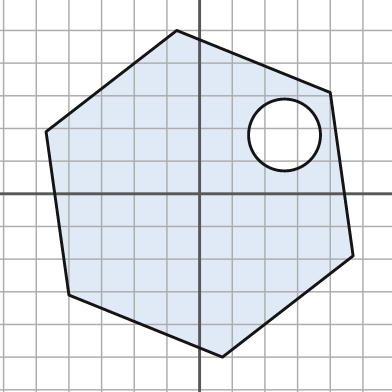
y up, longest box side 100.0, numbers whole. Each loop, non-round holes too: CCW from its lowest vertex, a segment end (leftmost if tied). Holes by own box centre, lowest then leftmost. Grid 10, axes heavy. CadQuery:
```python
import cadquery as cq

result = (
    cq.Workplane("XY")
    .moveTo(7.0, -50.0)
    .lineTo(47.0, -19.0)
    .lineTo(40.0, 31.0)
    .lineTo(-7.0, 50.0)
    .lineTo(-47.0, 19.0)
    .lineTo(-40.0, -31.0)
    .close()
    .moveTo(26.0, 18.0)
    .circle(11.0)
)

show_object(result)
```